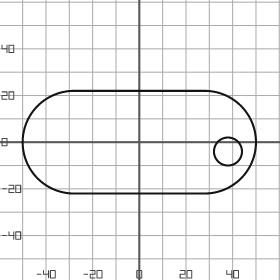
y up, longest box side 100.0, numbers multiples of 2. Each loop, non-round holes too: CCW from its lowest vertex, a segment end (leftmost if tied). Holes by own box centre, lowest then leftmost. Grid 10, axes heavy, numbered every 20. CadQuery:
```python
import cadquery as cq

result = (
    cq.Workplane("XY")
    .moveTo(-28.0, -22.0)
    .lineTo(28.0, -22.0)
    .threePointArc((50.0, 0.0), (28.0, 22.0))
    .lineTo(-28.0, 22.0)
    .threePointArc((-50.0, 0.0), (-28.0, -22.0))
    .close()
    .moveTo(38.0, -4.0)
    .circle(6.0)
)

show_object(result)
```